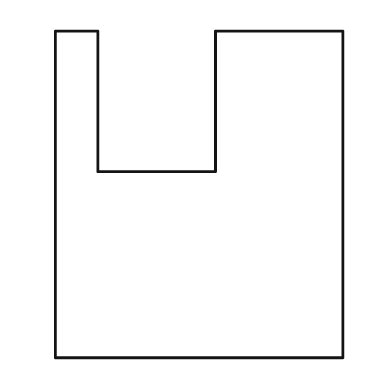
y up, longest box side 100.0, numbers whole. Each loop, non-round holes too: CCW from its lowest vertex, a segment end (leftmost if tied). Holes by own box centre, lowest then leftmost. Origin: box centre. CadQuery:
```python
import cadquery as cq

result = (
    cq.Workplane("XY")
    .moveTo(-44.0, -50.0)
    .lineTo(44.0, -50.0)
    .lineTo(44.0, 50.0)
    .lineTo(5.0, 50.0)
    .lineTo(5.0, 7.0)
    .lineTo(-31.0, 7.0)
    .lineTo(-31.0, 50.0)
    .lineTo(-44.0, 50.0)
    .close()
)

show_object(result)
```